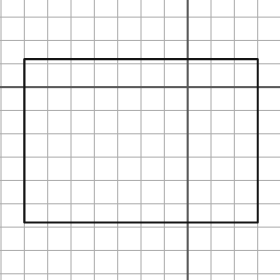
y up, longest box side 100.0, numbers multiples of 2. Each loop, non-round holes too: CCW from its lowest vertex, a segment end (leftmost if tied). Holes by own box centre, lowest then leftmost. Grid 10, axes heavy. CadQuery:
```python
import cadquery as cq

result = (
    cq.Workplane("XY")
    .moveTo(-70.0, -58.0)
    .lineTo(30.0, -58.0)
    .lineTo(30.0, 12.0)
    .lineTo(-70.0, 12.0)
    .close()
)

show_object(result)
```